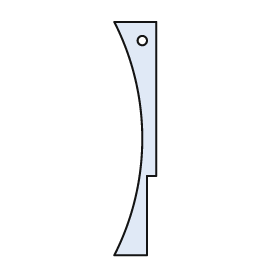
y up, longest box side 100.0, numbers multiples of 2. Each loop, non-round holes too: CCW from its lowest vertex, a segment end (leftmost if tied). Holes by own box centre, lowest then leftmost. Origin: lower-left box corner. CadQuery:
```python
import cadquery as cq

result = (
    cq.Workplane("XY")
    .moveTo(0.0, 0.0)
    .lineTo(14.0, 0.0)
    .lineTo(14.0, 34.0)
    .lineTo(18.0, 34.0)
    .lineTo(18.0, 100.0)
    .lineTo(0.0, 100.0)
    .threePointArc((12.0, 50.0), (0.0, 0.0))
    .close()
    .moveTo(12.0, 92.0)
    .circle(2.0)
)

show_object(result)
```